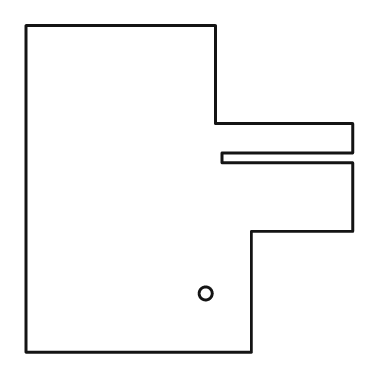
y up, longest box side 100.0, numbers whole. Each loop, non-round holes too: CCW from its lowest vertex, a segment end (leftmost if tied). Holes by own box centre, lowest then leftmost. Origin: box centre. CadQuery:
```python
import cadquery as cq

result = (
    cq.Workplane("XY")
    .moveTo(-50.0, -50.0)
    .lineTo(19.0, -50.0)
    .lineTo(19.0, -13.0)
    .lineTo(50.0, -13.0)
    .lineTo(50.0, 8.0)
    .lineTo(10.0, 8.0)
    .lineTo(10.0, 11.0)
    .lineTo(50.0, 11.0)
    .lineTo(50.0, 20.0)
    .lineTo(8.0, 20.0)
    .lineTo(8.0, 50.0)
    .lineTo(-50.0, 50.0)
    .close()
    .moveTo(5.0, -32.0)
    .circle(2.0)
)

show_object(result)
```